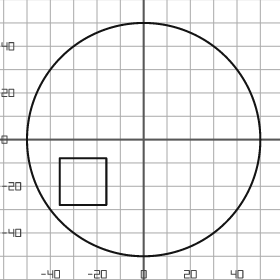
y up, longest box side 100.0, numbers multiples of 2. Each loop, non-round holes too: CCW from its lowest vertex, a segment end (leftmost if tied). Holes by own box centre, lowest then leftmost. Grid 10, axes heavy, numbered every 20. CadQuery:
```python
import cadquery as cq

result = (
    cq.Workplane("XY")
    .moveTo(0.0, 0.0)
    .circle(50.0)
    .moveTo(-36.0, -28.0)
    .lineTo(-16.0, -28.0)
    .lineTo(-16.0, -8.0)
    .lineTo(-36.0, -8.0)
    .close()
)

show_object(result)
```